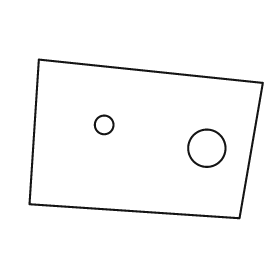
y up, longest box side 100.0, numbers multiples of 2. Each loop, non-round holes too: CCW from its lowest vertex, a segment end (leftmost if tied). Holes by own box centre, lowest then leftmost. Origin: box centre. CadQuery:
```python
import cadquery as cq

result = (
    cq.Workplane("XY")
    .moveTo(40.0, -34.0)
    .lineTo(50.0, 24.0)
    .lineTo(-46.0, 34.0)
    .lineTo(-50.0, -28.0)
    .close()
    .moveTo(26.0, -4.0)
    .circle(8.0)
    .moveTo(-18.0, 6.0)
    .circle(4.0)
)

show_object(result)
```